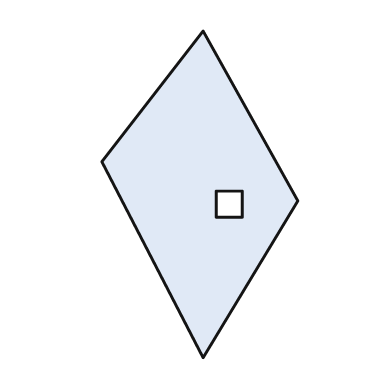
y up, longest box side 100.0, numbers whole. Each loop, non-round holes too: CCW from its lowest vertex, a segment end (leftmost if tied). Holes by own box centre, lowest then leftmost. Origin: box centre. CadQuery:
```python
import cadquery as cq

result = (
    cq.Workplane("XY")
    .moveTo(1.0, -50.0)
    .lineTo(30.0, -2.0)
    .lineTo(1.0, 50.0)
    .lineTo(-30.0, 10.0)
    .close()
    .moveTo(5.0, -7.0)
    .lineTo(13.0, -7.0)
    .lineTo(13.0, 1.0)
    .lineTo(5.0, 1.0)
    .close()
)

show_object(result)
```